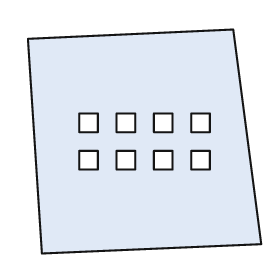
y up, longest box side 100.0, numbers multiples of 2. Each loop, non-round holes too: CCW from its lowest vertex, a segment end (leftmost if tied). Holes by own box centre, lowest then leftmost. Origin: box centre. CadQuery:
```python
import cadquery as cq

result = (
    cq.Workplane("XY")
    .moveTo(-44.0, -48.0)
    .lineTo(50.0, -44.0)
    .lineTo(38.0, 48.0)
    .lineTo(-50.0, 44.0)
    .close()
    .moveTo(-28.0, -12.0)
    .lineTo(-20.0, -12.0)
    .lineTo(-20.0, -4.0)
    .lineTo(-28.0, -4.0)
    .close()
    .moveTo(-12.0, -12.0)
    .lineTo(-4.0, -12.0)
    .lineTo(-4.0, -4.0)
    .lineTo(-12.0, -4.0)
    .close()
    .moveTo(4.0, -12.0)
    .lineTo(12.0, -12.0)
    .lineTo(12.0, -4.0)
    .lineTo(4.0, -4.0)
    .close()
    .moveTo(20.0, -12.0)
    .lineTo(28.0, -12.0)
    .lineTo(28.0, -4.0)
    .lineTo(20.0, -4.0)
    .close()
    .moveTo(-28.0, 4.0)
    .lineTo(-20.0, 4.0)
    .lineTo(-20.0, 12.0)
    .lineTo(-28.0, 12.0)
    .close()
    .moveTo(-12.0, 4.0)
    .lineTo(-4.0, 4.0)
    .lineTo(-4.0, 12.0)
    .lineTo(-12.0, 12.0)
    .close()
    .moveTo(4.0, 4.0)
    .lineTo(12.0, 4.0)
    .lineTo(12.0, 12.0)
    .lineTo(4.0, 12.0)
    .close()
    .moveTo(20.0, 4.0)
    .lineTo(28.0, 4.0)
    .lineTo(28.0, 12.0)
    .lineTo(20.0, 12.0)
    .close()
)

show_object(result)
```